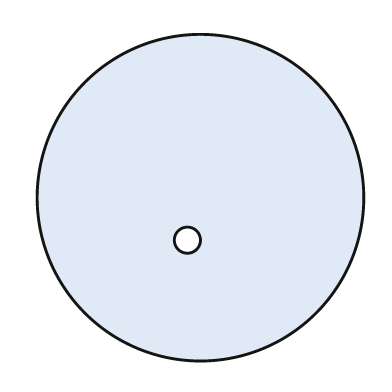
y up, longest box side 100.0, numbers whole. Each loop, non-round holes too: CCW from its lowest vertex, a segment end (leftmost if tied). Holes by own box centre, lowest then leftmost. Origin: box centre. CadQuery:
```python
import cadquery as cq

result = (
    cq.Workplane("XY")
    .moveTo(0.0, 0.0)
    .circle(50.0)
    .moveTo(-4.0, -13.0)
    .circle(4.0)
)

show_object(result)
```